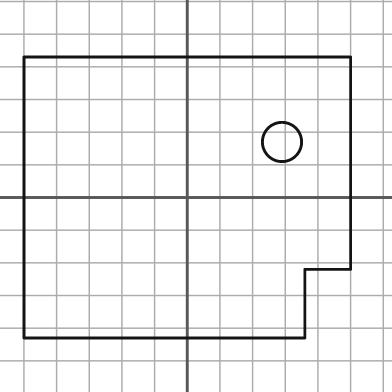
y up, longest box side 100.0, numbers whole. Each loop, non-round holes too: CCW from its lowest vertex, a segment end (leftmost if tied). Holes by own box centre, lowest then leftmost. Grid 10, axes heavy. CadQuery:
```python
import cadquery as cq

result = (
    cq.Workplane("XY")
    .moveTo(-50.0, -43.0)
    .lineTo(36.0, -43.0)
    .lineTo(36.0, -22.0)
    .lineTo(50.0, -22.0)
    .lineTo(50.0, 43.0)
    .lineTo(-50.0, 43.0)
    .close()
    .moveTo(29.0, 17.0)
    .circle(6.0)
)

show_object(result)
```